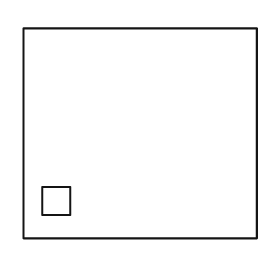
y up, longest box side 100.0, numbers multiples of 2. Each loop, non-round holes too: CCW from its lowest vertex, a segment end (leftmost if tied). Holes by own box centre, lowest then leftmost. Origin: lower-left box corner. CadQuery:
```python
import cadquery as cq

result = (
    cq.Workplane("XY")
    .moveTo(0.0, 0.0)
    .lineTo(100.0, 0.0)
    .lineTo(100.0, 90.0)
    .lineTo(0.0, 90.0)
    .close()
    .moveTo(8.0, 10.0)
    .lineTo(20.0, 10.0)
    .lineTo(20.0, 22.0)
    .lineTo(8.0, 22.0)
    .close()
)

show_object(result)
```